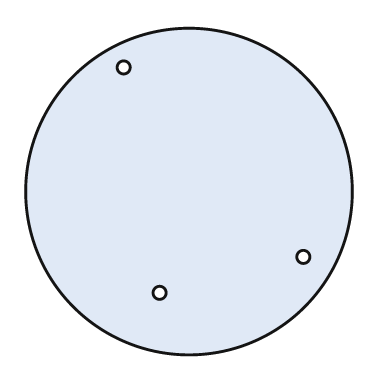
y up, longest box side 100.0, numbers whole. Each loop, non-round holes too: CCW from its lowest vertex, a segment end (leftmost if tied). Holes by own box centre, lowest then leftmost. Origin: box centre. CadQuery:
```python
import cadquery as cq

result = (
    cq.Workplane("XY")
    .moveTo(0.0, 0.0)
    .circle(50.0)
    .moveTo(-9.0, -31.0)
    .circle(2.0)
    .moveTo(35.0, -20.0)
    .circle(2.0)
    .moveTo(-20.0, 38.0)
    .circle(2.0)
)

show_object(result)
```